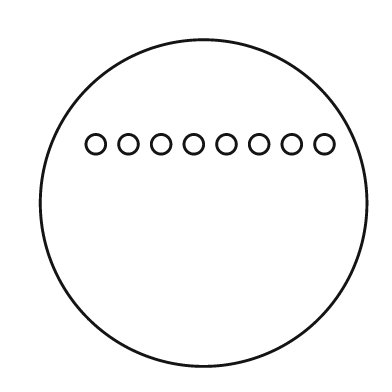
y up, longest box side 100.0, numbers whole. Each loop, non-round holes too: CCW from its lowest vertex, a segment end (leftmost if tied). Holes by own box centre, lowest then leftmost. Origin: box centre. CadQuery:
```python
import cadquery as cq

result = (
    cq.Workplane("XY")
    .moveTo(0.0, 0.0)
    .circle(50.0)
    .moveTo(-33.0, 18.0)
    .circle(3.0)
    .moveTo(-23.0, 18.0)
    .circle(3.0)
    .moveTo(-13.0, 18.0)
    .circle(3.0)
    .moveTo(-3.0, 18.0)
    .circle(3.0)
    .moveTo(7.0, 18.0)
    .circle(3.0)
    .moveTo(17.0, 18.0)
    .circle(3.0)
    .moveTo(27.0, 18.0)
    .circle(3.0)
    .moveTo(37.0, 18.0)
    .circle(3.0)
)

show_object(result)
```